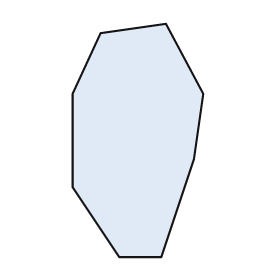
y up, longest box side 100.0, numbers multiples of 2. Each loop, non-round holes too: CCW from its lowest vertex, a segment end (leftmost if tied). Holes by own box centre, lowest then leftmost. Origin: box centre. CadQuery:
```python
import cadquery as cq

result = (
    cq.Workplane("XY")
    .moveTo(-8.0, -50.0)
    .lineTo(10.0, -50.0)
    .lineTo(24.0, -8.0)
    .lineTo(28.0, 20.0)
    .lineTo(12.0, 50.0)
    .lineTo(-16.0, 46.0)
    .lineTo(-28.0, 20.0)
    .lineTo(-28.0, -20.0)
    .close()
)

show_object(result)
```